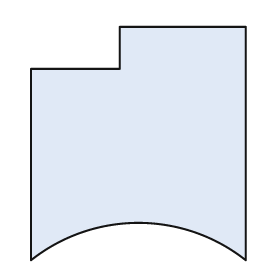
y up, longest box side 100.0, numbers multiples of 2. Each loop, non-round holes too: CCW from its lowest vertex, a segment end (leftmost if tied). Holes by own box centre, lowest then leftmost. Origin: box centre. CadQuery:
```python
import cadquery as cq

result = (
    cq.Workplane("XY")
    .moveTo(-46.0, -50.0)
    .threePointArc((0.0, -34.0), (46.0, -50.0))
    .lineTo(46.0, 50.0)
    .lineTo(-8.0, 50.0)
    .lineTo(-8.0, 32.0)
    .lineTo(-46.0, 32.0)
    .close()
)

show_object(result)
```